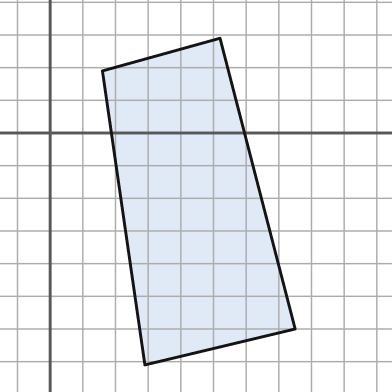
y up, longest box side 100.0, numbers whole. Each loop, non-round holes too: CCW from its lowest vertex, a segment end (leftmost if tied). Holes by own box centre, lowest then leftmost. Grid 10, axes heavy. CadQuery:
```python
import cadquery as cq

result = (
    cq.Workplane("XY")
    .moveTo(29.0, -71.0)
    .lineTo(75.0, -60.0)
    .lineTo(52.0, 29.0)
    .lineTo(16.0, 19.0)
    .close()
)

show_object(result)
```